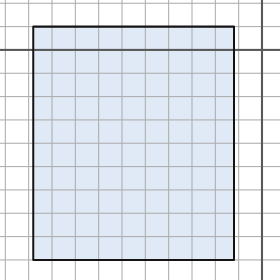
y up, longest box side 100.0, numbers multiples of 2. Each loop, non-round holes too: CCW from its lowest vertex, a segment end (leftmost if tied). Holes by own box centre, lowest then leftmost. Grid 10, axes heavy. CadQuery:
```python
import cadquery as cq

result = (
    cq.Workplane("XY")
    .moveTo(-98.0, -90.0)
    .lineTo(-12.0, -90.0)
    .lineTo(-12.0, 10.0)
    .lineTo(-98.0, 10.0)
    .close()
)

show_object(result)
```